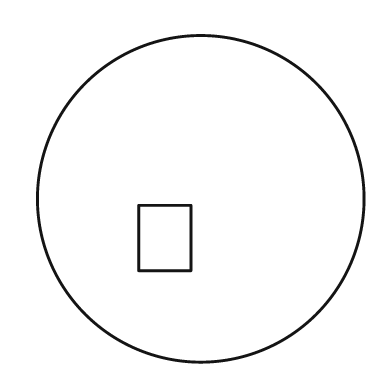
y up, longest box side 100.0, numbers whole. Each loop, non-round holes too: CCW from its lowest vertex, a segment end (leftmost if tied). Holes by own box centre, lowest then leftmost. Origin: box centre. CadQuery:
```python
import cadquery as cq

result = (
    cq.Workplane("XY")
    .moveTo(0.0, 0.0)
    .circle(50.0)
    .moveTo(-19.0, -22.0)
    .lineTo(-3.0, -22.0)
    .lineTo(-3.0, -2.0)
    .lineTo(-19.0, -2.0)
    .close()
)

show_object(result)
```